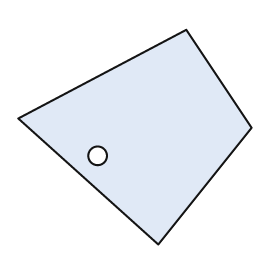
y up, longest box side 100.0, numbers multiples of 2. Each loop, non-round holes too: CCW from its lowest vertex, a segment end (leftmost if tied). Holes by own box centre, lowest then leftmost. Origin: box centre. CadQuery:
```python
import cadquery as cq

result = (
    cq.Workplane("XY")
    .moveTo(10.0, -46.0)
    .lineTo(50.0, 4.0)
    .lineTo(22.0, 46.0)
    .lineTo(-50.0, 8.0)
    .close()
    .moveTo(-16.0, -8.0)
    .circle(4.0)
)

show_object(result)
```